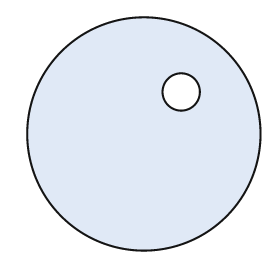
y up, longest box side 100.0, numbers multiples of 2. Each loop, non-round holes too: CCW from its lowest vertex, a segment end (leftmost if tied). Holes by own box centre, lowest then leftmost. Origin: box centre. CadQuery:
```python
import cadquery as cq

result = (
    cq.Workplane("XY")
    .moveTo(0.0, 0.0)
    .circle(50.0)
    .moveTo(16.0, 18.0)
    .circle(8.0)
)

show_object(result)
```